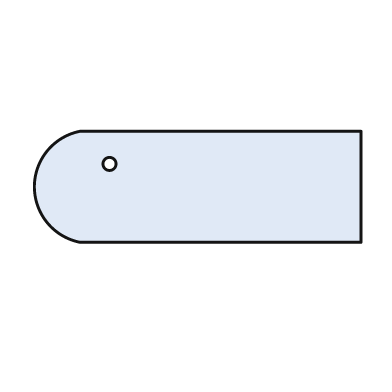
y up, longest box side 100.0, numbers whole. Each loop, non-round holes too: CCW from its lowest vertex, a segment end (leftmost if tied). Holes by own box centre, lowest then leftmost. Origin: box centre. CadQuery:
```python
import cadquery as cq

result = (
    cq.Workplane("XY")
    .moveTo(-36.0, -17.0)
    .lineTo(50.0, -17.0)
    .lineTo(50.0, 17.0)
    .lineTo(-36.0, 17.0)
    .threePointArc((-50.0, 0.0), (-36.0, -17.0))
    .close()
    .moveTo(-27.0, 7.0)
    .circle(2.0)
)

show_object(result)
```